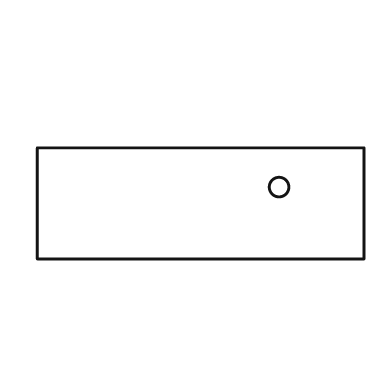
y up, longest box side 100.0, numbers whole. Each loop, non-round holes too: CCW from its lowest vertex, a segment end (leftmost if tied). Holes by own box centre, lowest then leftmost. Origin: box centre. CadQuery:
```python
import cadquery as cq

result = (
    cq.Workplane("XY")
    .moveTo(-50.0, -17.0)
    .lineTo(50.0, -17.0)
    .lineTo(50.0, 17.0)
    .lineTo(-50.0, 17.0)
    .close()
    .moveTo(24.0, 5.0)
    .circle(3.0)
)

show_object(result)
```